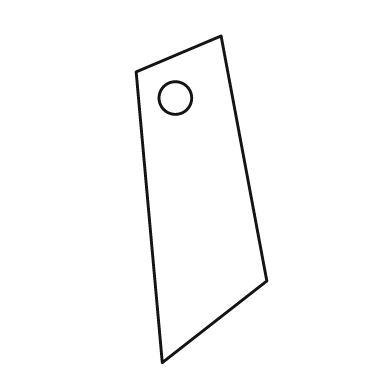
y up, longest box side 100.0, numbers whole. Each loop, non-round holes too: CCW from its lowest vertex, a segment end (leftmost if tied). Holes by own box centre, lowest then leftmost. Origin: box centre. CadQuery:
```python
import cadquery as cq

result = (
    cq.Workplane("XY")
    .moveTo(-12.0, -50.0)
    .lineTo(20.0, -25.0)
    .lineTo(6.0, 50.0)
    .lineTo(-20.0, 39.0)
    .close()
    .moveTo(-8.0, 31.0)
    .circle(5.0)
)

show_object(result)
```